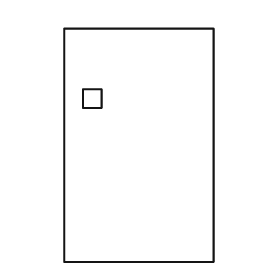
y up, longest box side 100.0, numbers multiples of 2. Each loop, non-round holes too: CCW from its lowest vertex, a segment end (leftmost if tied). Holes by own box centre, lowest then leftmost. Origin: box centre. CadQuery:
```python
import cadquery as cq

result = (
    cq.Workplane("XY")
    .moveTo(-32.0, -50.0)
    .lineTo(32.0, -50.0)
    .lineTo(32.0, 50.0)
    .lineTo(-32.0, 50.0)
    .close()
    .moveTo(-24.0, 16.0)
    .lineTo(-16.0, 16.0)
    .lineTo(-16.0, 24.0)
    .lineTo(-24.0, 24.0)
    .close()
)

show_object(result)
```